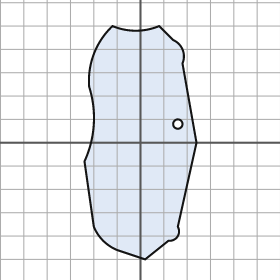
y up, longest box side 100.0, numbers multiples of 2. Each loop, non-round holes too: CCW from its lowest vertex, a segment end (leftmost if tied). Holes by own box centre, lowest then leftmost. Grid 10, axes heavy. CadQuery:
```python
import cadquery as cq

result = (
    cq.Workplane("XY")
    .moveTo(2.0, -50.0)
    .lineTo(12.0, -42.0)
    .threePointArc((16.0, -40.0), (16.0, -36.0))
    .lineTo(24.0, 0.0)
    .lineTo(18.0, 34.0)
    .threePointArc((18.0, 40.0), (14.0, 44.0))
    .lineTo(8.0, 50.0)
    .threePointArc((-2.0, 48.0), (-12.0, 50.0))
    .threePointArc((-20.0, 38.0), (-22.0, 24.0))
    .threePointArc((-20.0, 8.0), (-24.0, -8.0))
    .lineTo(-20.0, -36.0)
    .threePointArc((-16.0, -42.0), (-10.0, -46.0))
    .close()
    .moveTo(16.0, 8.0)
    .circle(2.0)
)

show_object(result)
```